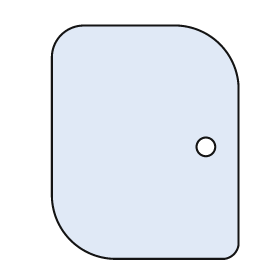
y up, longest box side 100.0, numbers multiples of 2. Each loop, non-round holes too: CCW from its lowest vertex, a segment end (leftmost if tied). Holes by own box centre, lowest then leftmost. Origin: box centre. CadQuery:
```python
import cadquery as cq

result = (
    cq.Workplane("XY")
    .moveTo(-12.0, -50.0)
    .lineTo(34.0, -50.0)
    .threePointArc((38.0, -48.0), (40.0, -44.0))
    .lineTo(40.0, 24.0)
    .threePointArc((32.0, 42.0), (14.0, 50.0))
    .lineTo(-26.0, 50.0)
    .threePointArc((-36.0, 46.0), (-40.0, 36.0))
    .lineTo(-40.0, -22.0)
    .threePointArc((-32.0, -42.0), (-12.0, -50.0))
    .close()
    .moveTo(26.0, -2.0)
    .circle(4.0)
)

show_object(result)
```